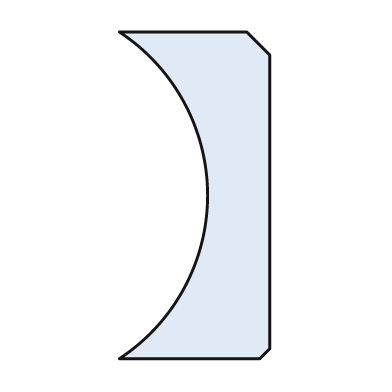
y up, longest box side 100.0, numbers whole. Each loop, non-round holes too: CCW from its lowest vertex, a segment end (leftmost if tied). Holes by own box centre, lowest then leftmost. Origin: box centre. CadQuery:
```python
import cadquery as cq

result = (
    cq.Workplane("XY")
    .moveTo(-23.0, -50.0)
    .lineTo(20.0, -50.0)
    .lineTo(23.0, -47.0)
    .lineTo(23.0, 43.0)
    .lineTo(16.0, 50.0)
    .lineTo(-23.0, 50.0)
    .threePointArc((4.0, 0.0), (-23.0, -50.0))
    .close()
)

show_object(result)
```